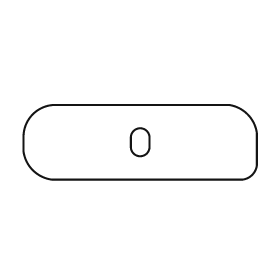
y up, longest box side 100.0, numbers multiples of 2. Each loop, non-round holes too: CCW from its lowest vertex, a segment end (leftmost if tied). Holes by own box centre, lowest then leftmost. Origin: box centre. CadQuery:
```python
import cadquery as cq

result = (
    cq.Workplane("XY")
    .moveTo(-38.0, -16.0)
    .lineTo(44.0, -16.0)
    .threePointArc((48.0, -14.0), (50.0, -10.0))
    .lineTo(50.0, 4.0)
    .threePointArc((46.0, 12.0), (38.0, 16.0))
    .lineTo(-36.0, 16.0)
    .threePointArc((-46.0, 12.0), (-50.0, 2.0))
    .lineTo(-50.0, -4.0)
    .threePointArc((-46.0, -12.0), (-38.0, -16.0))
    .close()
    .moveTo(-4.0, -2.0)
    .threePointArc((0.0, -6.0), (4.0, -2.0))
    .lineTo(4.0, 2.0)
    .threePointArc((0.0, 6.0), (-4.0, 2.0))
    .close()
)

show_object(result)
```